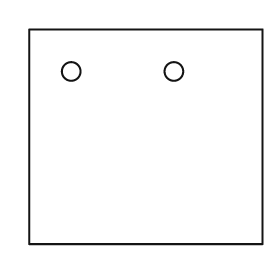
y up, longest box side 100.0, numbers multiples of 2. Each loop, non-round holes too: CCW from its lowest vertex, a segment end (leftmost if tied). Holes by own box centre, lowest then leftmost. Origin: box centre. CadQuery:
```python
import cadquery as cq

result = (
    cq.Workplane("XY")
    .moveTo(-50.0, -46.0)
    .lineTo(50.0, -46.0)
    .lineTo(50.0, 46.0)
    .lineTo(-50.0, 46.0)
    .close()
    .moveTo(-32.0, 28.0)
    .circle(4.0)
    .moveTo(12.0, 28.0)
    .circle(4.0)
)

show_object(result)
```